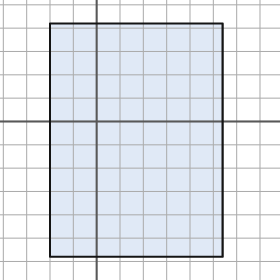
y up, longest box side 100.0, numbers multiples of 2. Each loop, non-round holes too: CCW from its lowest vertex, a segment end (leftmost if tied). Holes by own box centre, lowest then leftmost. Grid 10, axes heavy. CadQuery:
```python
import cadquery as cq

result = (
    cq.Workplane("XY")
    .moveTo(-20.0, -58.0)
    .lineTo(54.0, -58.0)
    .lineTo(54.0, 42.0)
    .lineTo(-20.0, 42.0)
    .close()
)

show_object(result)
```